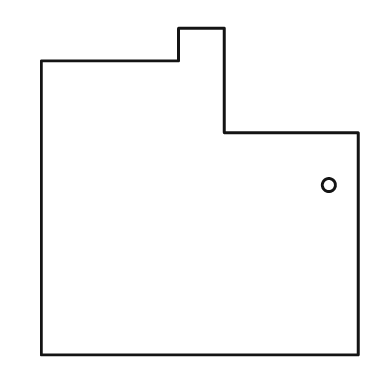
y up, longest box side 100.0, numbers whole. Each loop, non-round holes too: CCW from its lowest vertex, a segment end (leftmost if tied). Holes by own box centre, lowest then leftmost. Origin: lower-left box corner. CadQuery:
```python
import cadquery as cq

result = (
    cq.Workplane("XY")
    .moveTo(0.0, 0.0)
    .lineTo(97.0, 0.0)
    .lineTo(97.0, 68.0)
    .lineTo(56.0, 68.0)
    .lineTo(56.0, 100.0)
    .lineTo(42.0, 100.0)
    .lineTo(42.0, 90.0)
    .lineTo(0.0, 90.0)
    .close()
    .moveTo(88.0, 52.0)
    .circle(2.0)
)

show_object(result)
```